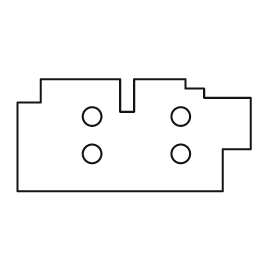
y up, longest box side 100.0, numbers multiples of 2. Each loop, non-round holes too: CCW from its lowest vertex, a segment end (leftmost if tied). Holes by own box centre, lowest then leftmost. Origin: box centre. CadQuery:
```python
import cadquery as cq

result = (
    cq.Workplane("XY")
    .moveTo(-50.0, -24.0)
    .lineTo(38.0, -24.0)
    .lineTo(38.0, -6.0)
    .lineTo(50.0, -6.0)
    .lineTo(50.0, 16.0)
    .lineTo(30.0, 16.0)
    .lineTo(30.0, 20.0)
    .lineTo(22.0, 20.0)
    .lineTo(22.0, 24.0)
    .lineTo(0.0, 24.0)
    .lineTo(0.0, 10.0)
    .lineTo(-6.0, 10.0)
    .lineTo(-6.0, 24.0)
    .lineTo(-40.0, 24.0)
    .lineTo(-40.0, 14.0)
    .lineTo(-50.0, 14.0)
    .close()
    .moveTo(-18.0, -8.0)
    .circle(4.0)
    .moveTo(20.0, -8.0)
    .circle(4.0)
    .moveTo(-18.0, 8.0)
    .circle(4.0)
    .moveTo(20.0, 8.0)
    .circle(4.0)
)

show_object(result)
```